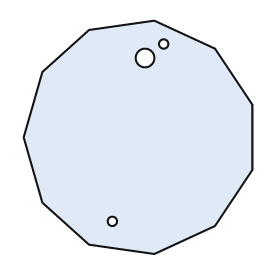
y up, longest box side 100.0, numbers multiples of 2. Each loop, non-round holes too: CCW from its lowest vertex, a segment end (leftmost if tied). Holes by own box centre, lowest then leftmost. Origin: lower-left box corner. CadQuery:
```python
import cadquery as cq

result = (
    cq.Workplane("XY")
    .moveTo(56.0, 0.0)
    .lineTo(82.0, 12.0)
    .lineTo(98.0, 36.0)
    .lineTo(98.0, 64.0)
    .lineTo(82.0, 88.0)
    .lineTo(56.0, 100.0)
    .lineTo(28.0, 96.0)
    .lineTo(8.0, 78.0)
    .lineTo(0.0, 50.0)
    .lineTo(8.0, 22.0)
    .lineTo(28.0, 4.0)
    .close()
    .moveTo(38.0, 14.0)
    .circle(2.0)
    .moveTo(52.0, 84.0)
    .circle(4.0)
    .moveTo(60.0, 90.0)
    .circle(2.0)
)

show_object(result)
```